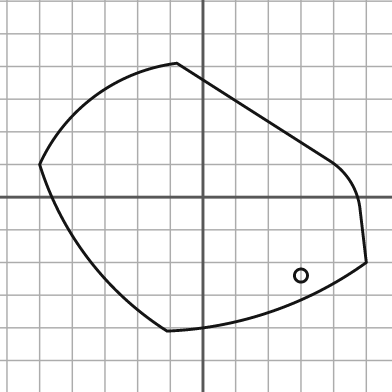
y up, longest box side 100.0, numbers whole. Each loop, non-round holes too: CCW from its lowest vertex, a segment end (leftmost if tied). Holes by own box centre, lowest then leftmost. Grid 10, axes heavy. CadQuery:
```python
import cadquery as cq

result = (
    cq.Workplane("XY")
    .moveTo(-11.0, -41.0)
    .threePointArc((21.0, -35.0), (50.0, -20.0))
    .lineTo(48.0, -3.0)
    .threePointArc((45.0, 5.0), (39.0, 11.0))
    .lineTo(-8.0, 41.0)
    .threePointArc((-33.0, 31.0), (-50.0, 10.0))
    .threePointArc((-35.0, -19.0), (-11.0, -41.0))
    .close()
    .moveTo(30.0, -24.0)
    .circle(2.0)
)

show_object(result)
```